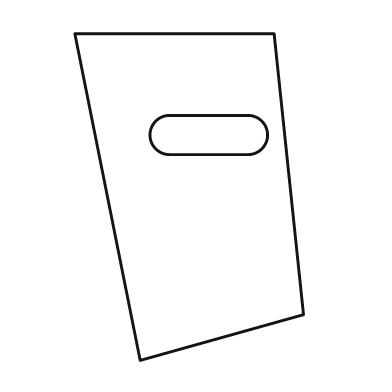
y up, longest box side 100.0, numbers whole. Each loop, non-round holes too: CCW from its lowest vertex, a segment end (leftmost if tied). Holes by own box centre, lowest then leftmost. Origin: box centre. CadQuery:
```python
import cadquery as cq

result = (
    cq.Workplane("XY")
    .moveTo(-15.0, -50.0)
    .lineTo(35.0, -36.0)
    .lineTo(26.0, 50.0)
    .lineTo(-35.0, 50.0)
    .close()
    .moveTo(-6.0, 13.0)
    .lineTo(18.0, 13.0)
    .threePointArc((24.0, 19.0), (18.0, 25.0))
    .lineTo(-6.0, 25.0)
    .threePointArc((-12.0, 19.0), (-6.0, 13.0))
    .close()
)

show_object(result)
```